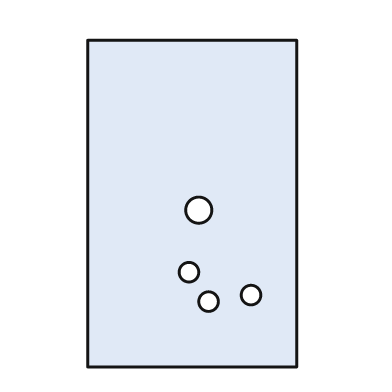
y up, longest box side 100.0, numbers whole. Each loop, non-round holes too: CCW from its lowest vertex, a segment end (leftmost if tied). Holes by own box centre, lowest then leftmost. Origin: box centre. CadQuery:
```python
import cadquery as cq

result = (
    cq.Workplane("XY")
    .moveTo(-32.0, -50.0)
    .lineTo(32.0, -50.0)
    .lineTo(32.0, 50.0)
    .lineTo(-32.0, 50.0)
    .close()
    .moveTo(5.0, -30.0)
    .circle(3.0)
    .moveTo(18.0, -28.0)
    .circle(3.0)
    .moveTo(-1.0, -21.0)
    .circle(3.0)
    .moveTo(2.0, -2.0)
    .circle(4.0)
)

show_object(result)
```